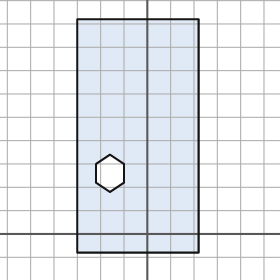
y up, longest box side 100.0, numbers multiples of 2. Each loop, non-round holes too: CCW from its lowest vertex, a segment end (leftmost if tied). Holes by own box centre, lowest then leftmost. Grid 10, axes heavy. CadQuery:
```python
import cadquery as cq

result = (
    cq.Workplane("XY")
    .moveTo(-30.0, -8.0)
    .lineTo(22.0, -8.0)
    .lineTo(22.0, 92.0)
    .lineTo(-30.0, 92.0)
    .close()
    .moveTo(-16.0, 18.0)
    .lineTo(-10.0, 22.0)
    .lineTo(-10.0, 30.0)
    .lineTo(-16.0, 34.0)
    .lineTo(-22.0, 30.0)
    .lineTo(-22.0, 22.0)
    .close()
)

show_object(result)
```